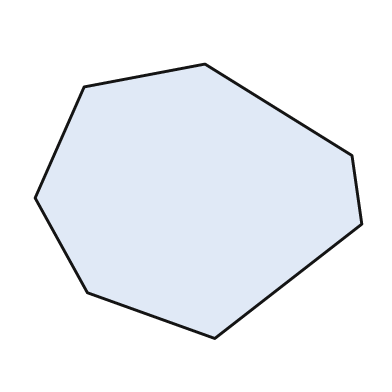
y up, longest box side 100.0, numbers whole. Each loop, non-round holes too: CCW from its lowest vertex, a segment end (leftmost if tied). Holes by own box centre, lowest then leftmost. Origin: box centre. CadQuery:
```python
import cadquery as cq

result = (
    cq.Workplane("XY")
    .moveTo(5.0, -42.0)
    .lineTo(50.0, -7.0)
    .lineTo(47.0, 14.0)
    .lineTo(2.0, 42.0)
    .lineTo(-35.0, 35.0)
    .lineTo(-50.0, 1.0)
    .lineTo(-34.0, -28.0)
    .close()
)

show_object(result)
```